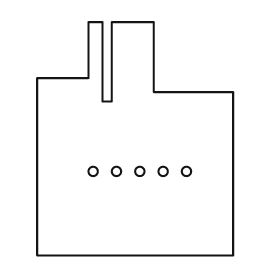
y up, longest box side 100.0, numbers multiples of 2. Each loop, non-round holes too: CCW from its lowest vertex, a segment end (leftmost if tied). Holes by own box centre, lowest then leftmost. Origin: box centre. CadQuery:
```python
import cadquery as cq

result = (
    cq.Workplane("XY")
    .moveTo(-42.0, -50.0)
    .lineTo(42.0, -50.0)
    .lineTo(42.0, 20.0)
    .lineTo(8.0, 20.0)
    .lineTo(8.0, 50.0)
    .lineTo(-10.0, 50.0)
    .lineTo(-10.0, 16.0)
    .lineTo(-14.0, 16.0)
    .lineTo(-14.0, 50.0)
    .lineTo(-20.0, 50.0)
    .lineTo(-20.0, 26.0)
    .lineTo(-42.0, 26.0)
    .close()
    .moveTo(-18.0, -14.0)
    .circle(2.0)
    .moveTo(-8.0, -14.0)
    .circle(2.0)
    .moveTo(2.0, -14.0)
    .circle(2.0)
    .moveTo(12.0, -14.0)
    .circle(2.0)
    .moveTo(22.0, -14.0)
    .circle(2.0)
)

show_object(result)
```